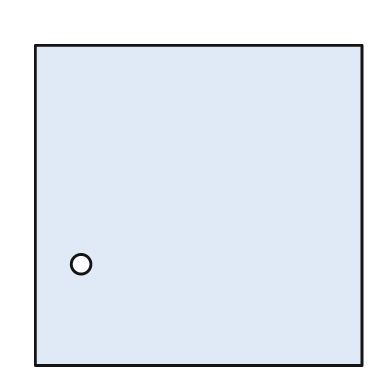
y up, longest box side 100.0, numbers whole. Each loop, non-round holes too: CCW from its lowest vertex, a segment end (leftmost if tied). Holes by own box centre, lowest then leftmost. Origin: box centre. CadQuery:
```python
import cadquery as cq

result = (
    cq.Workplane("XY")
    .moveTo(-50.0, -49.0)
    .lineTo(50.0, -49.0)
    .lineTo(50.0, 49.0)
    .lineTo(-50.0, 49.0)
    .close()
    .moveTo(-36.0, -18.0)
    .circle(3.0)
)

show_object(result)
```